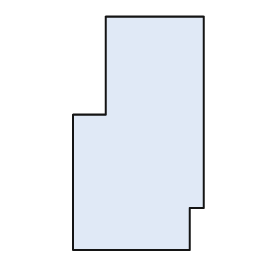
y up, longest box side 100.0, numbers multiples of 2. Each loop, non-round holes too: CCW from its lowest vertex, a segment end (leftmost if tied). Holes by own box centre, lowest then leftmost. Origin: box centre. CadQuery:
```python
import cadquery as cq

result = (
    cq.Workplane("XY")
    .moveTo(-28.0, -50.0)
    .lineTo(22.0, -50.0)
    .lineTo(22.0, -32.0)
    .lineTo(28.0, -32.0)
    .lineTo(28.0, 50.0)
    .lineTo(-14.0, 50.0)
    .lineTo(-14.0, 8.0)
    .lineTo(-28.0, 8.0)
    .close()
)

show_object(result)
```